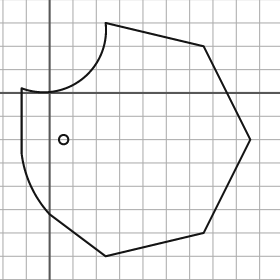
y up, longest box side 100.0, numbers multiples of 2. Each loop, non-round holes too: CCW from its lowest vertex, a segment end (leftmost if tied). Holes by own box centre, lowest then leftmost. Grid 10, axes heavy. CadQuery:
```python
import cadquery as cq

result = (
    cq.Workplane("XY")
    .moveTo(24.0, -70.0)
    .lineTo(66.0, -60.0)
    .lineTo(86.0, -20.0)
    .lineTo(66.0, 20.0)
    .lineTo(24.0, 30.0)
    .threePointArc((14.0, 6.0), (-12.0, 2.0))
    .lineTo(-12.0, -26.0)
    .threePointArc((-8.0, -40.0), (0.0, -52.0))
    .close()
    .moveTo(6.0, -20.0)
    .circle(2.0)
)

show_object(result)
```